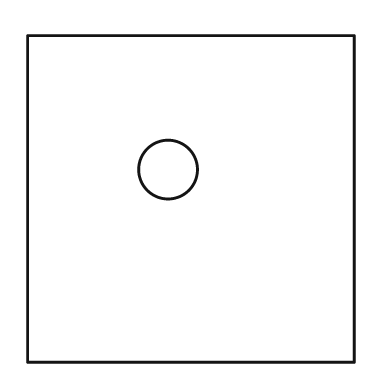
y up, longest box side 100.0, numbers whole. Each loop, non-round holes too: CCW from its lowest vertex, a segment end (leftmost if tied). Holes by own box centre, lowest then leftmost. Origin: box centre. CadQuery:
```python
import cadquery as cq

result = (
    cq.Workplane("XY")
    .moveTo(-50.0, -50.0)
    .lineTo(50.0, -50.0)
    .lineTo(50.0, 50.0)
    .lineTo(-50.0, 50.0)
    .close()
    .moveTo(-7.0, 9.0)
    .circle(9.0)
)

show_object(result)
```